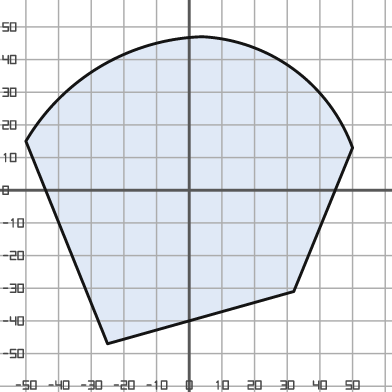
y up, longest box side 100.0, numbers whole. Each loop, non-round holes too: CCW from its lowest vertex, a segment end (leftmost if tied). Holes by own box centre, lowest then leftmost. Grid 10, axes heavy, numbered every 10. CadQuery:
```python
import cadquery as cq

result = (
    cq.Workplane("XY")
    .moveTo(-25.0, -47.0)
    .lineTo(32.0, -31.0)
    .lineTo(50.0, 13.0)
    .threePointArc((32.0, 37.0), (4.0, 47.0))
    .threePointArc((-27.0, 38.0), (-50.0, 15.0))
    .close()
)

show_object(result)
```